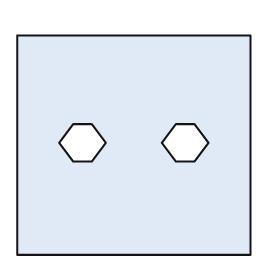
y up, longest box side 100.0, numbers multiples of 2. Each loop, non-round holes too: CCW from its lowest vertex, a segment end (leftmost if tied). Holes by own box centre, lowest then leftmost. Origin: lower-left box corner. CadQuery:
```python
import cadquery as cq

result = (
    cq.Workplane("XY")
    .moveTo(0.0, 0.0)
    .lineTo(100.0, 0.0)
    .lineTo(100.0, 94.0)
    .lineTo(0.0, 94.0)
    .close()
    .moveTo(24.0, 40.0)
    .lineTo(32.0, 40.0)
    .lineTo(38.0, 48.0)
    .lineTo(32.0, 56.0)
    .lineTo(24.0, 56.0)
    .lineTo(18.0, 48.0)
    .close()
    .moveTo(68.0, 40.0)
    .lineTo(76.0, 40.0)
    .lineTo(82.0, 48.0)
    .lineTo(76.0, 56.0)
    .lineTo(68.0, 56.0)
    .lineTo(62.0, 48.0)
    .close()
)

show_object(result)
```